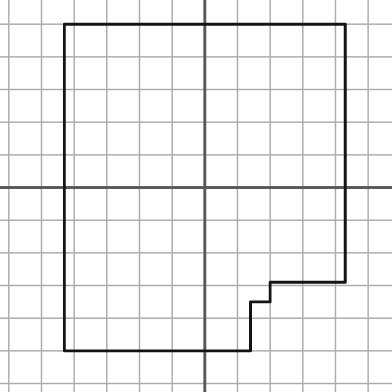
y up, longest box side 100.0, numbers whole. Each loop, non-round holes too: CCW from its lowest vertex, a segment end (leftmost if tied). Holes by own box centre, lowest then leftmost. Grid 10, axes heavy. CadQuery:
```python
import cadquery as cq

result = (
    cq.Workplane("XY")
    .moveTo(-43.0, -50.0)
    .lineTo(14.0, -50.0)
    .lineTo(14.0, -35.0)
    .lineTo(20.0, -35.0)
    .lineTo(20.0, -29.0)
    .lineTo(43.0, -29.0)
    .lineTo(43.0, 50.0)
    .lineTo(-43.0, 50.0)
    .close()
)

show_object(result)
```